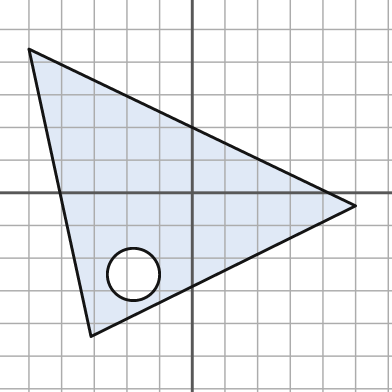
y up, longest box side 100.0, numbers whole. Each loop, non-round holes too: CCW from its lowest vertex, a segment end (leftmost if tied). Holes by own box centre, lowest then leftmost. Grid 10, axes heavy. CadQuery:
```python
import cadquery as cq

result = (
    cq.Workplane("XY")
    .moveTo(-31.0, -44.0)
    .lineTo(50.0, -4.0)
    .lineTo(-50.0, 44.0)
    .close()
    .moveTo(-18.0, -25.0)
    .circle(8.0)
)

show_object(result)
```